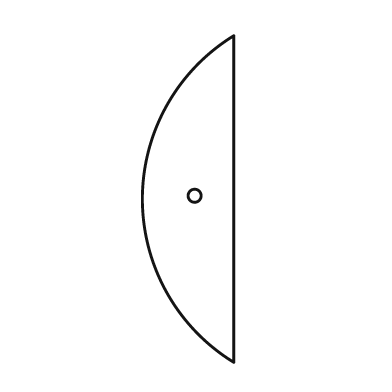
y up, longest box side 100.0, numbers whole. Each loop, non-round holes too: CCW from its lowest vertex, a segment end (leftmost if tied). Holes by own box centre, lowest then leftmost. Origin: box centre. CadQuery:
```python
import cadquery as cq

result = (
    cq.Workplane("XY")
    .moveTo(14.0, -50.0)
    .lineTo(14.0, 50.0)
    .threePointArc((-14.0, 0.0), (14.0, -50.0))
    .close()
    .moveTo(2.0, 1.0)
    .circle(2.0)
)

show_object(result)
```